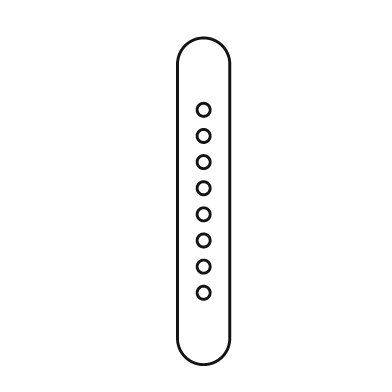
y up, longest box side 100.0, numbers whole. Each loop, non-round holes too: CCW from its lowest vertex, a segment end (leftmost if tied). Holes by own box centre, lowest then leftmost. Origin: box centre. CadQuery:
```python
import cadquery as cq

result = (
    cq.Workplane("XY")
    .moveTo(-8.0, -42.0)
    .threePointArc((0.0, -50.0), (8.0, -42.0))
    .lineTo(8.0, 42.0)
    .threePointArc((0.0, 50.0), (-8.0, 42.0))
    .close()
    .moveTo(0.0, -28.0)
    .circle(2.0)
    .moveTo(0.0, -20.0)
    .circle(2.0)
    .moveTo(0.0, -12.0)
    .circle(2.0)
    .moveTo(0.0, -4.0)
    .circle(2.0)
    .moveTo(0.0, 4.0)
    .circle(2.0)
    .moveTo(0.0, 12.0)
    .circle(2.0)
    .moveTo(0.0, 20.0)
    .circle(2.0)
    .moveTo(0.0, 28.0)
    .circle(2.0)
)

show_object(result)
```